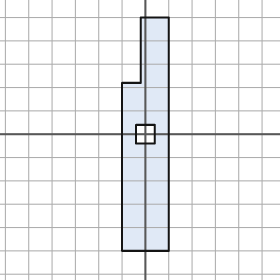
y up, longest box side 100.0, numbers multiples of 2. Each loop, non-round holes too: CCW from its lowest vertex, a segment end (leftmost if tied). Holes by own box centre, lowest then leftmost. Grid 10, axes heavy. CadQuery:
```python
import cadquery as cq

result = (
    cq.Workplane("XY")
    .moveTo(-10.0, -50.0)
    .lineTo(10.0, -50.0)
    .lineTo(10.0, 50.0)
    .lineTo(-2.0, 50.0)
    .lineTo(-2.0, 22.0)
    .lineTo(-10.0, 22.0)
    .close()
    .moveTo(-4.0, -4.0)
    .lineTo(4.0, -4.0)
    .lineTo(4.0, 4.0)
    .lineTo(-4.0, 4.0)
    .close()
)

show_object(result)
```